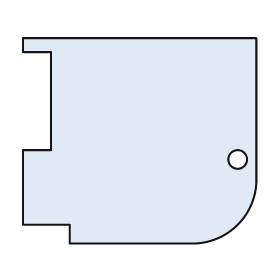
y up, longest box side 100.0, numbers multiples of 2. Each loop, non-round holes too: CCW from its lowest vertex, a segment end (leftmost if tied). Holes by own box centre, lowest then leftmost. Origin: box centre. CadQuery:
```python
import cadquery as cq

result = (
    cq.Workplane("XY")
    .moveTo(-30.0, -44.0)
    .lineTo(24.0, -44.0)
    .threePointArc((42.0, -36.0), (50.0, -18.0))
    .lineTo(50.0, 44.0)
    .lineTo(-50.0, 44.0)
    .lineTo(-50.0, 38.0)
    .lineTo(-38.0, 38.0)
    .lineTo(-38.0, -4.0)
    .lineTo(-50.0, -4.0)
    .lineTo(-50.0, -36.0)
    .lineTo(-30.0, -36.0)
    .close()
    .moveTo(42.0, -8.0)
    .circle(4.0)
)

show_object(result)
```